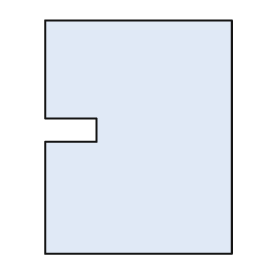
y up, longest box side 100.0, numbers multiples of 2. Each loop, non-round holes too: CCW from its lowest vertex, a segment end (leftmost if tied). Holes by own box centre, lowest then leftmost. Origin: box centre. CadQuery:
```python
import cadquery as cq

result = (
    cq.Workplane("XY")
    .moveTo(-40.0, -50.0)
    .lineTo(40.0, -50.0)
    .lineTo(40.0, 50.0)
    .lineTo(-40.0, 50.0)
    .lineTo(-40.0, 8.0)
    .lineTo(-18.0, 8.0)
    .lineTo(-18.0, -2.0)
    .lineTo(-40.0, -2.0)
    .close()
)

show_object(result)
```